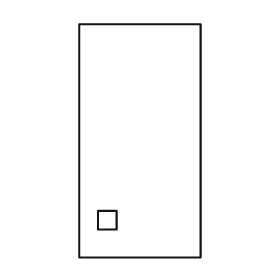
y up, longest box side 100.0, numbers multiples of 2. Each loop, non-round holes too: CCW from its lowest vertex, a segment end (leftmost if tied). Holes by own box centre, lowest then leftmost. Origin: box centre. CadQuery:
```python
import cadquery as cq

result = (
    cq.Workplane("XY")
    .moveTo(-26.0, -50.0)
    .lineTo(26.0, -50.0)
    .lineTo(26.0, 50.0)
    .lineTo(-26.0, 50.0)
    .close()
    .moveTo(-18.0, -38.0)
    .lineTo(-10.0, -38.0)
    .lineTo(-10.0, -30.0)
    .lineTo(-18.0, -30.0)
    .close()
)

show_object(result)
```